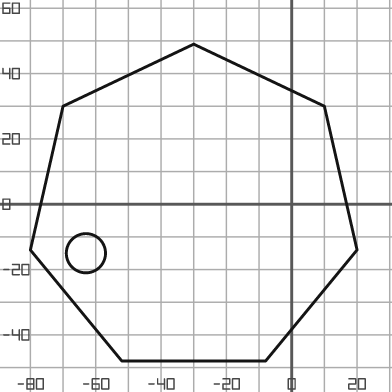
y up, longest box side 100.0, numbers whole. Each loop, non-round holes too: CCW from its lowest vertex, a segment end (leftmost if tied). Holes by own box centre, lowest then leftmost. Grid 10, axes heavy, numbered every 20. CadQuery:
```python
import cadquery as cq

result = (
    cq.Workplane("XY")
    .moveTo(-52.0, -48.0)
    .lineTo(-8.0, -48.0)
    .lineTo(20.0, -14.0)
    .lineTo(10.0, 30.0)
    .lineTo(-30.0, 49.0)
    .lineTo(-70.0, 30.0)
    .lineTo(-80.0, -14.0)
    .close()
    .moveTo(-63.0, -15.0)
    .circle(6.0)
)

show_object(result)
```